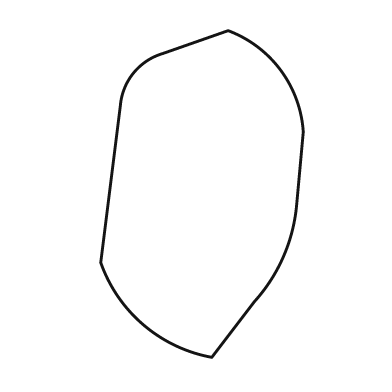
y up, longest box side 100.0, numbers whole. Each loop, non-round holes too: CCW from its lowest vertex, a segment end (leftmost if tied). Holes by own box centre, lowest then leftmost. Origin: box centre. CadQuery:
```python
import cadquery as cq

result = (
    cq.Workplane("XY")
    .moveTo(3.0, -50.0)
    .lineTo(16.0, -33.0)
    .threePointArc((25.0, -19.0), (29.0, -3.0))
    .lineTo(31.0, 19.0)
    .threePointArc((24.0, 38.0), (8.0, 50.0))
    .lineTo(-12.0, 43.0)
    .threePointArc((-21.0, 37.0), (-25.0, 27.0))
    .lineTo(-31.0, -21.0)
    .threePointArc((-18.0, -40.0), (3.0, -50.0))
    .close()
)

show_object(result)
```